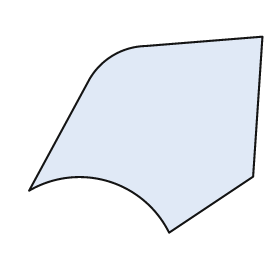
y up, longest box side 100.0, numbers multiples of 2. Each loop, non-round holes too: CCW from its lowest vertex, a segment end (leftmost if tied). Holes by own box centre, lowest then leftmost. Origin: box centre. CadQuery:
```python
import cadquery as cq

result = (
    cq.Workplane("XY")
    .moveTo(10.0, -42.0)
    .lineTo(46.0, -18.0)
    .lineTo(50.0, 42.0)
    .lineTo(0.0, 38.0)
    .threePointArc((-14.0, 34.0), (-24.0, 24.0))
    .lineTo(-50.0, -24.0)
    .threePointArc((-16.0, -20.0), (10.0, -42.0))
    .close()
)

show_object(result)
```